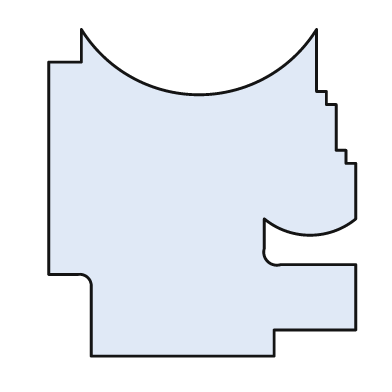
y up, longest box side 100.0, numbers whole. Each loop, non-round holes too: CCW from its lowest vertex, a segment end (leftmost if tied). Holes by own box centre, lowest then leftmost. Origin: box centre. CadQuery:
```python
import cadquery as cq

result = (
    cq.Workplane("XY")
    .moveTo(-34.0, -50.0)
    .lineTo(22.0, -50.0)
    .lineTo(22.0, -42.0)
    .lineTo(47.0, -42.0)
    .lineTo(47.0, -22.0)
    .lineTo(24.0, -22.0)
    .threePointArc((20.0, -21.0), (19.0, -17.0))
    .lineTo(19.0, -8.0)
    .threePointArc((33.0, -13.0), (47.0, -8.0))
    .lineTo(47.0, 9.0)
    .lineTo(44.0, 9.0)
    .lineTo(44.0, 13.0)
    .lineTo(41.0, 13.0)
    .lineTo(41.0, 27.0)
    .lineTo(38.0, 27.0)
    .lineTo(38.0, 31.0)
    .lineTo(35.0, 31.0)
    .lineTo(35.0, 50.0)
    .threePointArc((-1.0, 30.0), (-37.0, 50.0))
    .lineTo(-37.0, 40.0)
    .lineTo(-47.0, 40.0)
    .lineTo(-47.0, -25.0)
    .lineTo(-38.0, -25.0)
    .threePointArc((-35.0, -26.0), (-34.0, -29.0))
    .close()
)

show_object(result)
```